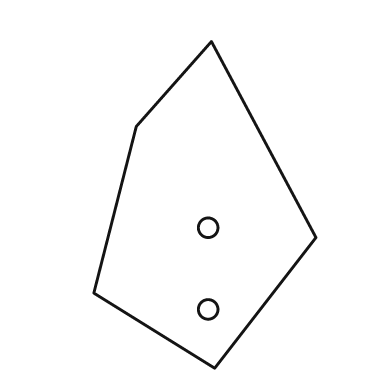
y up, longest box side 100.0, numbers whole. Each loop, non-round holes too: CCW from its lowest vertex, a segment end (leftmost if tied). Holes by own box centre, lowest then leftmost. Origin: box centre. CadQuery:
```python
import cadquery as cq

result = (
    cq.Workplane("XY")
    .moveTo(3.0, -50.0)
    .lineTo(34.0, -10.0)
    .lineTo(2.0, 50.0)
    .lineTo(-21.0, 24.0)
    .lineTo(-34.0, -27.0)
    .close()
    .moveTo(1.0, -32.0)
    .circle(3.0)
    .moveTo(1.0, -7.0)
    .circle(3.0)
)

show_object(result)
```